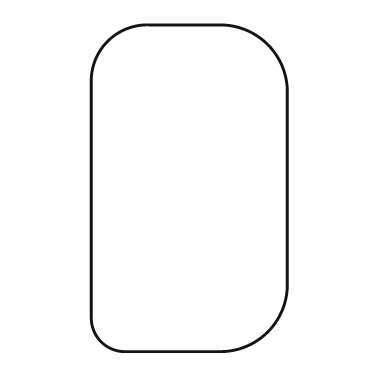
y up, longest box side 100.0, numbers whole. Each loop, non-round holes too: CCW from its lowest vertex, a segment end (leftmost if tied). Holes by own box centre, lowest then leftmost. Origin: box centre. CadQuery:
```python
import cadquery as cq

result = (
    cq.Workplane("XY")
    .moveTo(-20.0, -50.0)
    .lineTo(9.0, -50.0)
    .threePointArc((24.0, -44.0), (30.0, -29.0))
    .lineTo(30.0, 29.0)
    .threePointArc((24.0, 44.0), (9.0, 50.0))
    .lineTo(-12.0, 50.0)
    .threePointArc((-25.0, 45.0), (-30.0, 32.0))
    .lineTo(-30.0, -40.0)
    .threePointArc((-27.0, -47.0), (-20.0, -50.0))
    .close()
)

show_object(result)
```